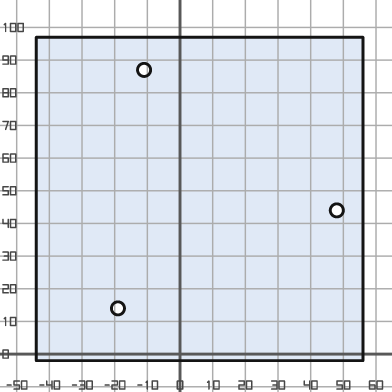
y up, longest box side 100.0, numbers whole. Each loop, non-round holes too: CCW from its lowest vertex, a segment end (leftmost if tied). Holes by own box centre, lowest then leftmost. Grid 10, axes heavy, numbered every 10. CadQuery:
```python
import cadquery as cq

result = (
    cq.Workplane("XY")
    .moveTo(-44.0, -2.0)
    .lineTo(56.0, -2.0)
    .lineTo(56.0, 97.0)
    .lineTo(-44.0, 97.0)
    .close()
    .moveTo(-19.0, 14.0)
    .circle(2.0)
    .moveTo(48.0, 44.0)
    .circle(2.0)
    .moveTo(-11.0, 87.0)
    .circle(2.0)
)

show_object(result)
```